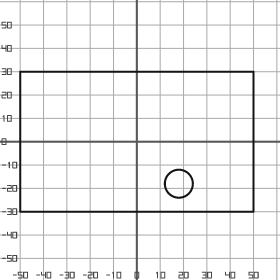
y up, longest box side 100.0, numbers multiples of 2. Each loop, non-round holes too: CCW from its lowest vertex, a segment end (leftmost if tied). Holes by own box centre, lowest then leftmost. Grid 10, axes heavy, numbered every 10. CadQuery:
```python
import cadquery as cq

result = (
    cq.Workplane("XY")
    .moveTo(-50.0, -30.0)
    .lineTo(50.0, -30.0)
    .lineTo(50.0, 30.0)
    .lineTo(-50.0, 30.0)
    .close()
    .moveTo(18.0, -18.0)
    .circle(6.0)
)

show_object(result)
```